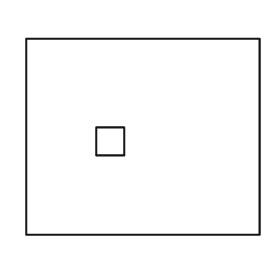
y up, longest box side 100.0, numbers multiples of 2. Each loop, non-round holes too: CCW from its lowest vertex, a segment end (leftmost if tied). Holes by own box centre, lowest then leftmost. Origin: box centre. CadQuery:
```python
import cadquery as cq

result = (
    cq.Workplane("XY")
    .moveTo(-50.0, -42.0)
    .lineTo(50.0, -42.0)
    .lineTo(50.0, 42.0)
    .lineTo(-50.0, 42.0)
    .close()
    .moveTo(-20.0, -8.0)
    .lineTo(-8.0, -8.0)
    .lineTo(-8.0, 4.0)
    .lineTo(-20.0, 4.0)
    .close()
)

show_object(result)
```